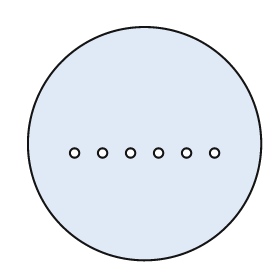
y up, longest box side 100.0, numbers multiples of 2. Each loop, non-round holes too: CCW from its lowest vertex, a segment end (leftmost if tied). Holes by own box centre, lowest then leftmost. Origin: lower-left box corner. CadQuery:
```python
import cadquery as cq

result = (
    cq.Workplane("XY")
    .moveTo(50.0, 50.0)
    .circle(50.0)
    .moveTo(20.0, 46.0)
    .circle(2.0)
    .moveTo(32.0, 46.0)
    .circle(2.0)
    .moveTo(44.0, 46.0)
    .circle(2.0)
    .moveTo(56.0, 46.0)
    .circle(2.0)
    .moveTo(68.0, 46.0)
    .circle(2.0)
    .moveTo(80.0, 46.0)
    .circle(2.0)
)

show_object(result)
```